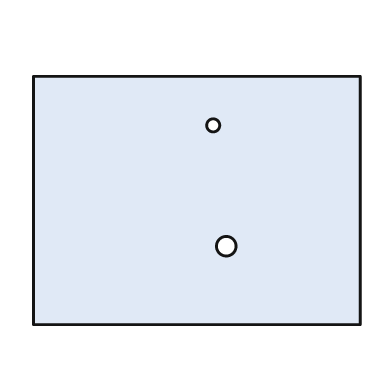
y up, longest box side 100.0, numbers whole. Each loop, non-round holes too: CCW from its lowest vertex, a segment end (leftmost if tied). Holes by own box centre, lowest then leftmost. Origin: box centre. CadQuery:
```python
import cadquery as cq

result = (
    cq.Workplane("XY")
    .moveTo(-50.0, -38.0)
    .lineTo(50.0, -38.0)
    .lineTo(50.0, 38.0)
    .lineTo(-50.0, 38.0)
    .close()
    .moveTo(9.0, -14.0)
    .circle(3.0)
    .moveTo(5.0, 23.0)
    .circle(2.0)
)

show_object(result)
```